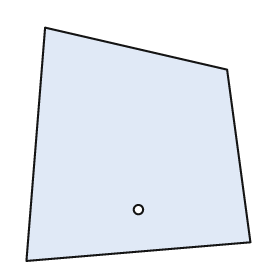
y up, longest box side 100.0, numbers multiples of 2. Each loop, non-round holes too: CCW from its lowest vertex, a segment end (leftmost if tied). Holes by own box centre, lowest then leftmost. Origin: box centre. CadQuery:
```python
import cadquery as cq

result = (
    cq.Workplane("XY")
    .moveTo(-48.0, -50.0)
    .lineTo(48.0, -42.0)
    .lineTo(38.0, 32.0)
    .lineTo(-40.0, 50.0)
    .close()
    .moveTo(0.0, -28.0)
    .circle(2.0)
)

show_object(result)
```